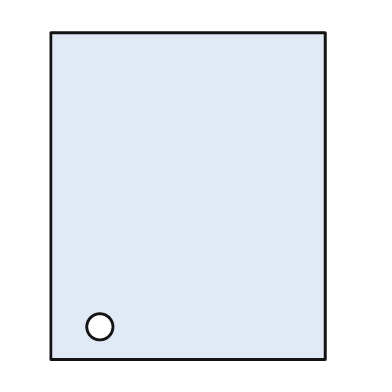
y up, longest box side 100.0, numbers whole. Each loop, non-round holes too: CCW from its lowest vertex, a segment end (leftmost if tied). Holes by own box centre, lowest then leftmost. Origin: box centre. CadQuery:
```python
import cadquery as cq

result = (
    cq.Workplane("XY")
    .moveTo(-42.0, -50.0)
    .lineTo(42.0, -50.0)
    .lineTo(42.0, 50.0)
    .lineTo(-42.0, 50.0)
    .close()
    .moveTo(-27.0, -40.0)
    .circle(4.0)
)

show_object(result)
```